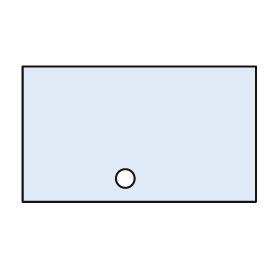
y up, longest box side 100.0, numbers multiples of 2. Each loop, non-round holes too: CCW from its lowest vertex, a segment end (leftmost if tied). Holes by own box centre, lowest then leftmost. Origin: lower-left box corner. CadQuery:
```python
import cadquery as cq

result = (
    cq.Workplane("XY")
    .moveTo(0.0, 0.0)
    .lineTo(100.0, 0.0)
    .lineTo(100.0, 58.0)
    .lineTo(0.0, 58.0)
    .close()
    .moveTo(44.0, 10.0)
    .circle(4.0)
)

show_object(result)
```